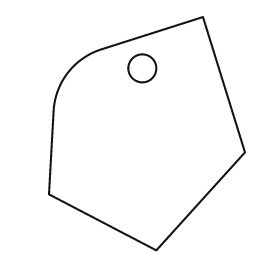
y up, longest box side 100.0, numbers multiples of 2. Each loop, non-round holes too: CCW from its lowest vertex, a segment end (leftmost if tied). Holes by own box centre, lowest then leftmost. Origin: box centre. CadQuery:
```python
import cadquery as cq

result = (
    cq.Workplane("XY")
    .moveTo(4.0, -50.0)
    .lineTo(42.0, -8.0)
    .lineTo(24.0, 50.0)
    .lineTo(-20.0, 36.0)
    .threePointArc((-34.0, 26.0), (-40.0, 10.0))
    .lineTo(-42.0, -26.0)
    .close()
    .moveTo(-2.0, 28.0)
    .circle(6.0)
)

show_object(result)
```